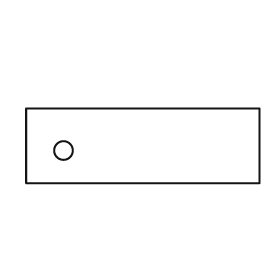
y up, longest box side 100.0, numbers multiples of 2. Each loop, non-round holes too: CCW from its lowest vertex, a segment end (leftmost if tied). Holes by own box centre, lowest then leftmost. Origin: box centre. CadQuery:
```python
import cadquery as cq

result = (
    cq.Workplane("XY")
    .moveTo(-50.0, -16.0)
    .lineTo(50.0, -16.0)
    .lineTo(50.0, 16.0)
    .lineTo(-50.0, 16.0)
    .close()
    .moveTo(-34.0, -2.0)
    .circle(4.0)
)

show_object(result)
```